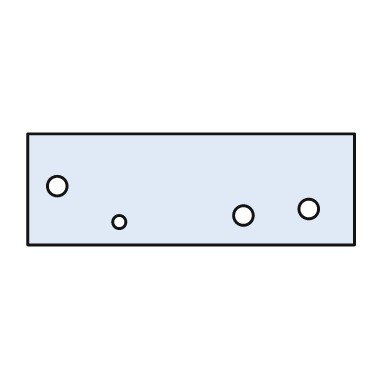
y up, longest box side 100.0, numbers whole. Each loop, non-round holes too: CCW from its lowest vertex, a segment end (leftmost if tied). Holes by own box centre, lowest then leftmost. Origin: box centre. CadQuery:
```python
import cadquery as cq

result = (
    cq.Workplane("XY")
    .moveTo(-50.0, -17.0)
    .lineTo(50.0, -17.0)
    .lineTo(50.0, 17.0)
    .lineTo(-50.0, 17.0)
    .close()
    .moveTo(-22.0, -10.0)
    .circle(2.0)
    .moveTo(16.0, -8.0)
    .circle(3.0)
    .moveTo(36.0, -6.0)
    .circle(3.0)
    .moveTo(-41.0, 1.0)
    .circle(3.0)
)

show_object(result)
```